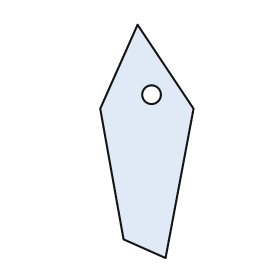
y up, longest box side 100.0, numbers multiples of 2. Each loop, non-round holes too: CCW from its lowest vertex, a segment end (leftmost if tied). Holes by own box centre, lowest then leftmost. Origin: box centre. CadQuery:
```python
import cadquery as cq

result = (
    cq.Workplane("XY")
    .moveTo(8.0, -50.0)
    .lineTo(20.0, 14.0)
    .lineTo(-4.0, 50.0)
    .lineTo(-20.0, 14.0)
    .lineTo(-10.0, -42.0)
    .close()
    .moveTo(2.0, 20.0)
    .circle(4.0)
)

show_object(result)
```